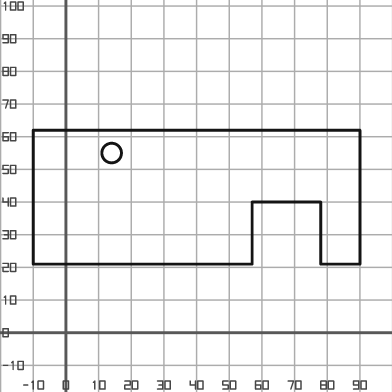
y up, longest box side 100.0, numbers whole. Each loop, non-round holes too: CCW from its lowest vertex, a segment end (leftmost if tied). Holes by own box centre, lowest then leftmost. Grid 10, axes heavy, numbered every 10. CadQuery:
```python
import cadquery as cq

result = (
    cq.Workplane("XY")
    .moveTo(-10.0, 21.0)
    .lineTo(57.0, 21.0)
    .lineTo(57.0, 40.0)
    .lineTo(78.0, 40.0)
    .lineTo(78.0, 21.0)
    .lineTo(90.0, 21.0)
    .lineTo(90.0, 62.0)
    .lineTo(-10.0, 62.0)
    .close()
    .moveTo(14.0, 55.0)
    .circle(3.0)
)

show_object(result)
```